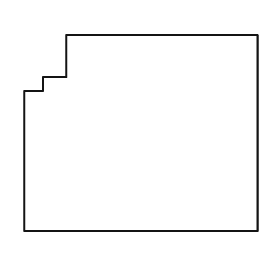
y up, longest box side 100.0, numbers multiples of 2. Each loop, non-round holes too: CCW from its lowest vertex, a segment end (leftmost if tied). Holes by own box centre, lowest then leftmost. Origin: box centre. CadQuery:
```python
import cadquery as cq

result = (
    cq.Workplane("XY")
    .moveTo(-50.0, -42.0)
    .lineTo(50.0, -42.0)
    .lineTo(50.0, 42.0)
    .lineTo(-32.0, 42.0)
    .lineTo(-32.0, 24.0)
    .lineTo(-42.0, 24.0)
    .lineTo(-42.0, 18.0)
    .lineTo(-50.0, 18.0)
    .close()
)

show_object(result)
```